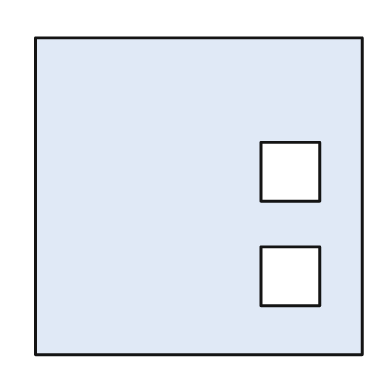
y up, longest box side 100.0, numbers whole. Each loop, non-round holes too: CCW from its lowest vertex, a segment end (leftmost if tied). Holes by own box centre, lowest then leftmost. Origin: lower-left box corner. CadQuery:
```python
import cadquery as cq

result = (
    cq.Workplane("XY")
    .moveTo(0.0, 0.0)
    .lineTo(100.0, 0.0)
    .lineTo(100.0, 97.0)
    .lineTo(0.0, 97.0)
    .close()
    .moveTo(69.0, 15.0)
    .lineTo(87.0, 15.0)
    .lineTo(87.0, 33.0)
    .lineTo(69.0, 33.0)
    .close()
    .moveTo(69.0, 47.0)
    .lineTo(87.0, 47.0)
    .lineTo(87.0, 65.0)
    .lineTo(69.0, 65.0)
    .close()
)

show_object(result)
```